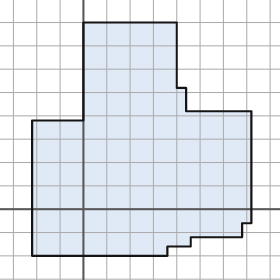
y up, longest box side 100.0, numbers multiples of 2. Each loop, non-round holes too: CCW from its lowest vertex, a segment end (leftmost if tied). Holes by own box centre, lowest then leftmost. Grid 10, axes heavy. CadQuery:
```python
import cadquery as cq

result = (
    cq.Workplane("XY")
    .moveTo(-22.0, -20.0)
    .lineTo(36.0, -20.0)
    .lineTo(36.0, -16.0)
    .lineTo(46.0, -16.0)
    .lineTo(46.0, -12.0)
    .lineTo(68.0, -12.0)
    .lineTo(68.0, -6.0)
    .lineTo(72.0, -6.0)
    .lineTo(72.0, 42.0)
    .lineTo(44.0, 42.0)
    .lineTo(44.0, 52.0)
    .lineTo(40.0, 52.0)
    .lineTo(40.0, 80.0)
    .lineTo(0.0, 80.0)
    .lineTo(0.0, 38.0)
    .lineTo(-22.0, 38.0)
    .close()
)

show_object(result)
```